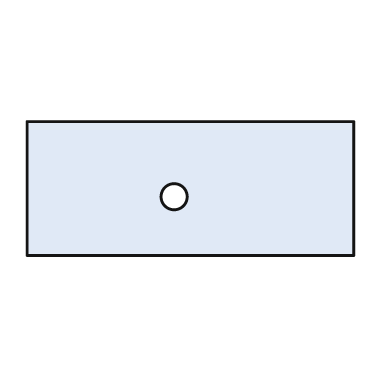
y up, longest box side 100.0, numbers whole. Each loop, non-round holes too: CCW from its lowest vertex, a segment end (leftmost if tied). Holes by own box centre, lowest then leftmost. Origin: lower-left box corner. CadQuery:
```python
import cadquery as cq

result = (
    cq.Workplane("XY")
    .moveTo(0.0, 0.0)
    .lineTo(100.0, 0.0)
    .lineTo(100.0, 41.0)
    .lineTo(0.0, 41.0)
    .close()
    .moveTo(45.0, 18.0)
    .circle(4.0)
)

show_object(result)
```